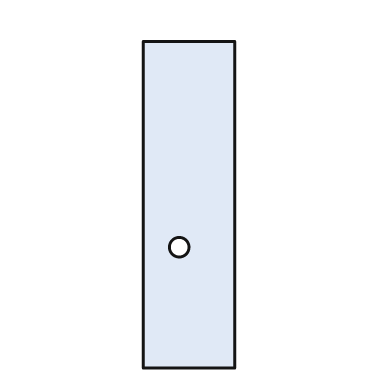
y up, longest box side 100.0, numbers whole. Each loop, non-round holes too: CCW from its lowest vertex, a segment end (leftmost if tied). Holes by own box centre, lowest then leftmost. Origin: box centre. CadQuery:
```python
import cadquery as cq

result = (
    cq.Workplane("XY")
    .moveTo(-14.0, -50.0)
    .lineTo(14.0, -50.0)
    .lineTo(14.0, 50.0)
    .lineTo(-14.0, 50.0)
    .close()
    .moveTo(-3.0, -13.0)
    .circle(3.0)
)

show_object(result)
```